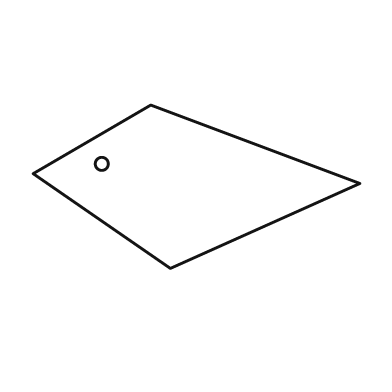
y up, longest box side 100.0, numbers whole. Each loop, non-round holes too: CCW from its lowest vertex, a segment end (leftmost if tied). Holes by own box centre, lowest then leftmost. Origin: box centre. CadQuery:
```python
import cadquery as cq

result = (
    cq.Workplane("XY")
    .moveTo(-8.0, -25.0)
    .lineTo(50.0, 1.0)
    .lineTo(-14.0, 25.0)
    .lineTo(-50.0, 4.0)
    .close()
    .moveTo(-29.0, 7.0)
    .circle(2.0)
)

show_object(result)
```